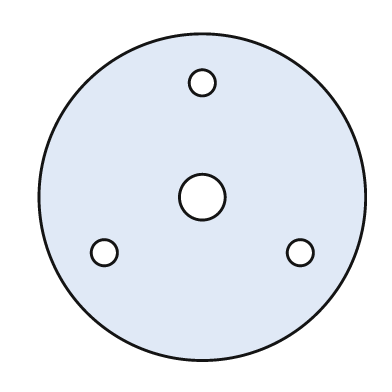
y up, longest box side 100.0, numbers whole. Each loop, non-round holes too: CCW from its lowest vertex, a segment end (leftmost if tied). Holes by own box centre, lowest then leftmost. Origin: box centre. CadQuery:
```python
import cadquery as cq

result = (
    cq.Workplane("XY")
    .moveTo(0.0, 0.0)
    .circle(50.0)
    .moveTo(-30.0, -17.0)
    .circle(4.0)
    .moveTo(30.0, -17.0)
    .circle(4.0)
    .moveTo(0.0, 0.0)
    .circle(7.0)
    .moveTo(0.0, 35.0)
    .circle(4.0)
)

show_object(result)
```